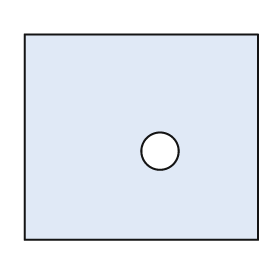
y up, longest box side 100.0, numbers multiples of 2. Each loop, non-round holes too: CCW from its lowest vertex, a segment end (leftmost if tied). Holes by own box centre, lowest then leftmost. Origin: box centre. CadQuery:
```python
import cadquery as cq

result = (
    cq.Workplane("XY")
    .moveTo(-50.0, -44.0)
    .lineTo(50.0, -44.0)
    .lineTo(50.0, 44.0)
    .lineTo(-50.0, 44.0)
    .close()
    .moveTo(8.0, -6.0)
    .circle(8.0)
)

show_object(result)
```